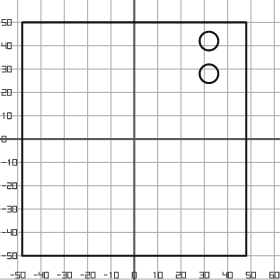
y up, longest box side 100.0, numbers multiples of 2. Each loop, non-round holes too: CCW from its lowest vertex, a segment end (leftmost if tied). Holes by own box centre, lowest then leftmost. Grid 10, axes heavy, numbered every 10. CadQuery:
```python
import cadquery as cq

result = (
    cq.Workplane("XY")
    .moveTo(-48.0, -50.0)
    .lineTo(48.0, -50.0)
    .lineTo(48.0, 50.0)
    .lineTo(-48.0, 50.0)
    .close()
    .moveTo(32.0, 28.0)
    .circle(4.0)
    .moveTo(32.0, 42.0)
    .circle(4.0)
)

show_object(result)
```